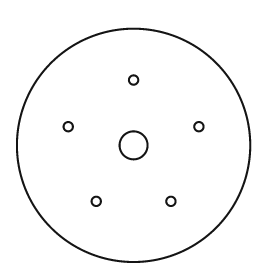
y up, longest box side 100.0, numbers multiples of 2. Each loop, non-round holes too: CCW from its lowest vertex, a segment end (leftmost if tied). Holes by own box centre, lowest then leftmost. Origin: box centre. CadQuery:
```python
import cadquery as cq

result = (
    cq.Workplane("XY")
    .moveTo(0.0, 0.0)
    .circle(50.0)
    .moveTo(-16.0, -24.0)
    .circle(2.0)
    .moveTo(16.0, -24.0)
    .circle(2.0)
    .moveTo(0.0, 0.0)
    .circle(6.0)
    .moveTo(-28.0, 8.0)
    .circle(2.0)
    .moveTo(28.0, 8.0)
    .circle(2.0)
    .moveTo(0.0, 28.0)
    .circle(2.0)
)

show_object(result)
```